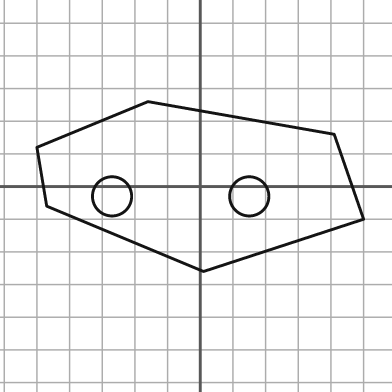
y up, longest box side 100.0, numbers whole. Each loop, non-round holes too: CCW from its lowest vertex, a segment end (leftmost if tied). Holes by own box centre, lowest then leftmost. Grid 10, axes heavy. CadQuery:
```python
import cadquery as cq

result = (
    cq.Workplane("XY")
    .moveTo(1.0, -26.0)
    .lineTo(50.0, -10.0)
    .lineTo(41.0, 16.0)
    .lineTo(-16.0, 26.0)
    .lineTo(-50.0, 12.0)
    .lineTo(-47.0, -6.0)
    .close()
    .moveTo(-27.0, -3.0)
    .circle(6.0)
    .moveTo(15.0, -3.0)
    .circle(6.0)
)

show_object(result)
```